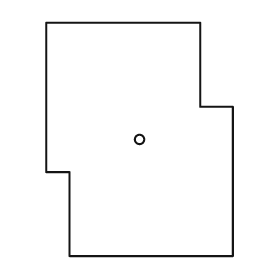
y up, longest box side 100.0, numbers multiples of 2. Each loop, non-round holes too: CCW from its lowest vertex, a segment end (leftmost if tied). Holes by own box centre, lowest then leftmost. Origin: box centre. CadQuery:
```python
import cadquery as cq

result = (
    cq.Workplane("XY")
    .moveTo(-30.0, -50.0)
    .lineTo(40.0, -50.0)
    .lineTo(40.0, 14.0)
    .lineTo(26.0, 14.0)
    .lineTo(26.0, 50.0)
    .lineTo(-40.0, 50.0)
    .lineTo(-40.0, -14.0)
    .lineTo(-30.0, -14.0)
    .close()
    .moveTo(0.0, 0.0)
    .circle(2.0)
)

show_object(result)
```